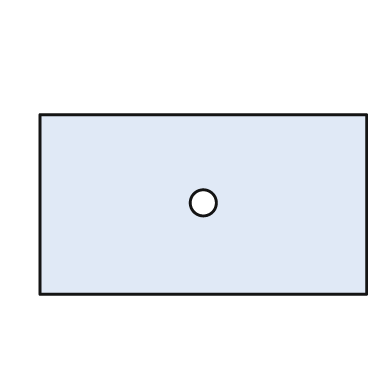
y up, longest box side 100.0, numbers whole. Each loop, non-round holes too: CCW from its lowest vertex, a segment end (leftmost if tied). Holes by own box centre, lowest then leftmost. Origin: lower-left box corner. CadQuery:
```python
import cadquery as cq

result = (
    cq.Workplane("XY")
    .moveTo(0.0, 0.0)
    .lineTo(100.0, 0.0)
    .lineTo(100.0, 55.0)
    .lineTo(0.0, 55.0)
    .close()
    .moveTo(50.0, 28.0)
    .circle(4.0)
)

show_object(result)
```